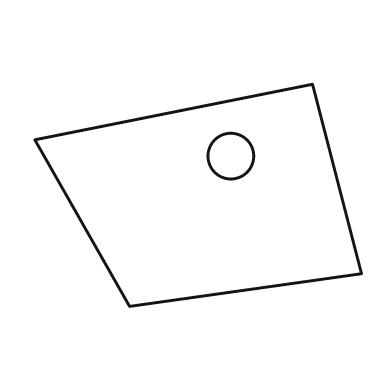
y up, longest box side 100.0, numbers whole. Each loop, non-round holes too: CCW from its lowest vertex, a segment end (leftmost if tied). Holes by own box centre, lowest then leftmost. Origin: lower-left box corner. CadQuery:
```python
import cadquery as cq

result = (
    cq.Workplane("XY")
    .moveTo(29.0, 0.0)
    .lineTo(100.0, 10.0)
    .lineTo(85.0, 68.0)
    .lineTo(0.0, 51.0)
    .close()
    .moveTo(60.0, 46.0)
    .circle(7.0)
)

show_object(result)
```